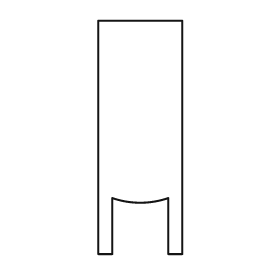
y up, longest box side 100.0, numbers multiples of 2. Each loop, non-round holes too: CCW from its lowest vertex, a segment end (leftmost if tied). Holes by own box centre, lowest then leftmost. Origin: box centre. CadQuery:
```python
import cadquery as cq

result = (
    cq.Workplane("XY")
    .moveTo(-18.0, -50.0)
    .lineTo(-12.0, -50.0)
    .lineTo(-12.0, -26.0)
    .threePointArc((0.0, -28.0), (12.0, -26.0))
    .lineTo(12.0, -50.0)
    .lineTo(18.0, -50.0)
    .lineTo(18.0, 50.0)
    .lineTo(-18.0, 50.0)
    .close()
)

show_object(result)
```